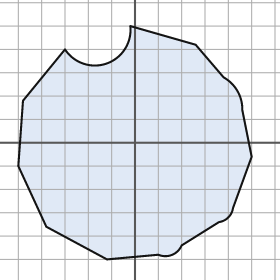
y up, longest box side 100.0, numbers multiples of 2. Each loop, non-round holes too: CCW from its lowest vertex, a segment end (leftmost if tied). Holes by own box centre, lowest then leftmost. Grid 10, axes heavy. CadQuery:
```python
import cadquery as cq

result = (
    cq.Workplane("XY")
    .moveTo(-12.0, -50.0)
    .lineTo(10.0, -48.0)
    .threePointArc((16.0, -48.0), (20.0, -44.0))
    .lineTo(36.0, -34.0)
    .threePointArc((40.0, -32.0), (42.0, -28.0))
    .lineTo(50.0, -6.0)
    .lineTo(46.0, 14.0)
    .threePointArc((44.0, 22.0), (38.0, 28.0))
    .lineTo(26.0, 42.0)
    .lineTo(-2.0, 50.0)
    .threePointArc((-12.0, 34.0), (-30.0, 40.0))
    .lineTo(-48.0, 18.0)
    .lineTo(-50.0, -10.0)
    .lineTo(-38.0, -36.0)
    .close()
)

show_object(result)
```